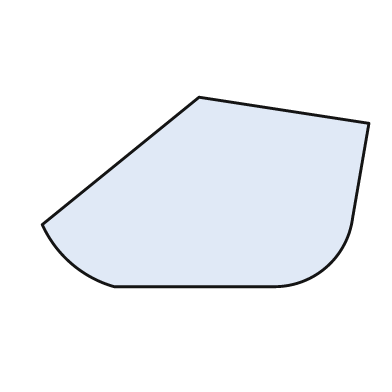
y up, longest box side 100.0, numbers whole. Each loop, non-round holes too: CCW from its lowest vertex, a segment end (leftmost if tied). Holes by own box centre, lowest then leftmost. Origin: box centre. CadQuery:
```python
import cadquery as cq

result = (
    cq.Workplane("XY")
    .moveTo(-28.0, -29.0)
    .lineTo(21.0, -29.0)
    .threePointArc((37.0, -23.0), (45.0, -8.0))
    .lineTo(50.0, 21.0)
    .lineTo(-2.0, 29.0)
    .lineTo(-50.0, -10.0)
    .threePointArc((-41.0, -22.0), (-28.0, -29.0))
    .close()
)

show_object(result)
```